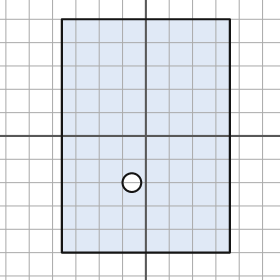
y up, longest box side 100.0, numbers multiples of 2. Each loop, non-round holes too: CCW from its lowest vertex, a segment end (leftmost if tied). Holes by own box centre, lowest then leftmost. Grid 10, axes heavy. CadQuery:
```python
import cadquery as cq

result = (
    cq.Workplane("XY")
    .moveTo(-36.0, -50.0)
    .lineTo(36.0, -50.0)
    .lineTo(36.0, 50.0)
    .lineTo(-36.0, 50.0)
    .close()
    .moveTo(-6.0, -20.0)
    .circle(4.0)
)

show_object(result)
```